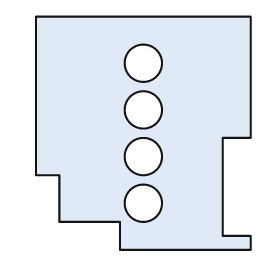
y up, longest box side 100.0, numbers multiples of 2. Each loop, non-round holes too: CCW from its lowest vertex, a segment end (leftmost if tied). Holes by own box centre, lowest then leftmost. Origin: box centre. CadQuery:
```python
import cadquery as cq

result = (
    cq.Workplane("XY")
    .moveTo(-10.0, -50.0)
    .lineTo(46.0, -50.0)
    .lineTo(46.0, -44.0)
    .lineTo(34.0, -44.0)
    .lineTo(34.0, -2.0)
    .lineTo(46.0, -2.0)
    .lineTo(46.0, 50.0)
    .lineTo(-46.0, 50.0)
    .lineTo(-46.0, -18.0)
    .lineTo(-36.0, -18.0)
    .lineTo(-36.0, -38.0)
    .lineTo(-10.0, -38.0)
    .close()
    .moveTo(0.0, -30.0)
    .circle(8.0)
    .moveTo(0.0, -10.0)
    .circle(8.0)
    .moveTo(0.0, 10.0)
    .circle(8.0)
    .moveTo(0.0, 30.0)
    .circle(8.0)
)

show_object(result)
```